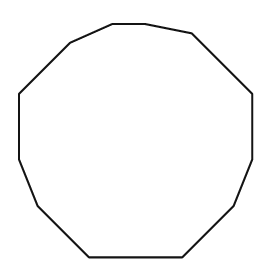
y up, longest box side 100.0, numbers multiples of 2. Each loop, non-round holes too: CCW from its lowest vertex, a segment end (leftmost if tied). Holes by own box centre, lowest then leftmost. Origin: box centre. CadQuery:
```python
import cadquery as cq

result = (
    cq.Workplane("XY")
    .moveTo(-20.0, -50.0)
    .lineTo(20.0, -50.0)
    .lineTo(42.0, -28.0)
    .lineTo(50.0, -8.0)
    .lineTo(50.0, 20.0)
    .lineTo(24.0, 46.0)
    .lineTo(4.0, 50.0)
    .lineTo(-10.0, 50.0)
    .lineTo(-28.0, 42.0)
    .lineTo(-50.0, 20.0)
    .lineTo(-50.0, -8.0)
    .lineTo(-42.0, -28.0)
    .close()
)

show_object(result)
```